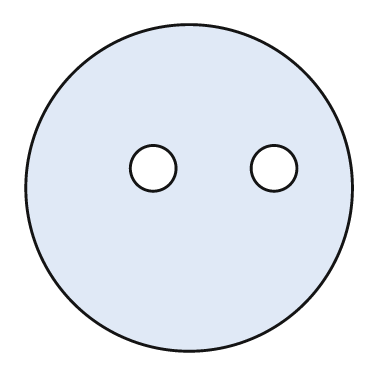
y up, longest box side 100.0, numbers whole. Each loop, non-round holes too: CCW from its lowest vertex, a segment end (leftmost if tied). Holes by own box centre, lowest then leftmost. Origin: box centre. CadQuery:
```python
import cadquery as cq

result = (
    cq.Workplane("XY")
    .moveTo(0.0, 0.0)
    .circle(50.0)
    .moveTo(-11.0, 6.0)
    .circle(7.0)
    .moveTo(26.0, 6.0)
    .circle(7.0)
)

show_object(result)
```